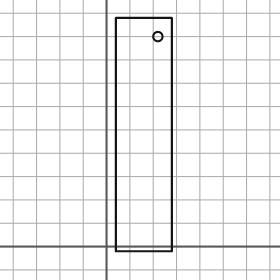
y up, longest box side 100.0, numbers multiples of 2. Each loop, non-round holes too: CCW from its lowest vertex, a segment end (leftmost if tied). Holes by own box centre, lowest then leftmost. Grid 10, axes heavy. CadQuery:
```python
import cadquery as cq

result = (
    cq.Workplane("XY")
    .moveTo(4.0, -2.0)
    .lineTo(28.0, -2.0)
    .lineTo(28.0, 98.0)
    .lineTo(4.0, 98.0)
    .close()
    .moveTo(22.0, 90.0)
    .circle(2.0)
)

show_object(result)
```